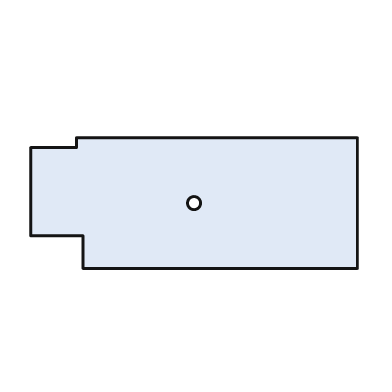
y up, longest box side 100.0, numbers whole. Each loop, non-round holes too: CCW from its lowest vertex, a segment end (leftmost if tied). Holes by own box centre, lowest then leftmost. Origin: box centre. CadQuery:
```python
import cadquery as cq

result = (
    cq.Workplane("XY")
    .moveTo(-34.0, -20.0)
    .lineTo(50.0, -20.0)
    .lineTo(50.0, 20.0)
    .lineTo(-36.0, 20.0)
    .lineTo(-36.0, 17.0)
    .lineTo(-50.0, 17.0)
    .lineTo(-50.0, -10.0)
    .lineTo(-34.0, -10.0)
    .close()
    .moveTo(0.0, 0.0)
    .circle(2.0)
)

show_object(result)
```